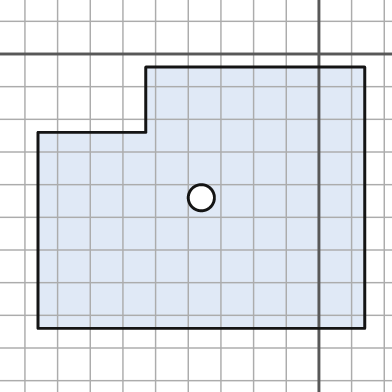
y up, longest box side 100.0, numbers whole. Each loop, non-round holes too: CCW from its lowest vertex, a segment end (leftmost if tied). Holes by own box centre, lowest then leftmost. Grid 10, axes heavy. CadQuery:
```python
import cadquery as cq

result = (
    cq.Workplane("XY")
    .moveTo(-86.0, -84.0)
    .lineTo(14.0, -84.0)
    .lineTo(14.0, -4.0)
    .lineTo(-53.0, -4.0)
    .lineTo(-53.0, -24.0)
    .lineTo(-86.0, -24.0)
    .close()
    .moveTo(-36.0, -44.0)
    .circle(4.0)
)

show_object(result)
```